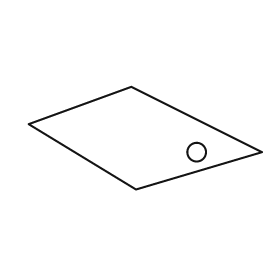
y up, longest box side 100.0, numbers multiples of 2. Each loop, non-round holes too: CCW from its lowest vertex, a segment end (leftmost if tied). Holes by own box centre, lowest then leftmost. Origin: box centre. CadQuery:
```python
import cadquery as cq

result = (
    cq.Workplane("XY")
    .moveTo(-4.0, -22.0)
    .lineTo(50.0, -6.0)
    .lineTo(-6.0, 22.0)
    .lineTo(-50.0, 6.0)
    .close()
    .moveTo(22.0, -6.0)
    .circle(4.0)
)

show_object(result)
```